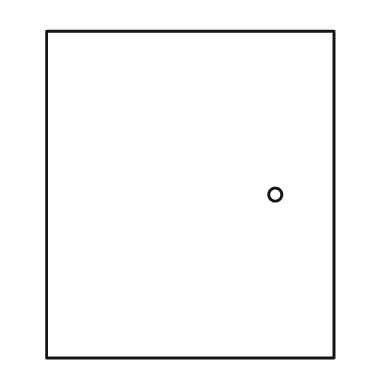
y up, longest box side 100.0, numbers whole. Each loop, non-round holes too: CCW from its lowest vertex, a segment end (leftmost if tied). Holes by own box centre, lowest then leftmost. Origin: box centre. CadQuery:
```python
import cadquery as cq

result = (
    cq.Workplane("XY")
    .moveTo(-44.0, -50.0)
    .lineTo(44.0, -50.0)
    .lineTo(44.0, 50.0)
    .lineTo(-44.0, 50.0)
    .close()
    .moveTo(26.0, 0.0)
    .circle(2.0)
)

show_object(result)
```